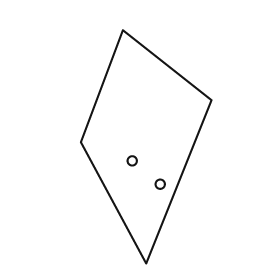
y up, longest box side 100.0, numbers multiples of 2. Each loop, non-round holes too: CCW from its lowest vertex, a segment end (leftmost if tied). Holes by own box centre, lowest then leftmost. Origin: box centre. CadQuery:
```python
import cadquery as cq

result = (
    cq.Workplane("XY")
    .moveTo(0.0, -50.0)
    .lineTo(28.0, 20.0)
    .lineTo(-10.0, 50.0)
    .lineTo(-28.0, 2.0)
    .close()
    .moveTo(6.0, -16.0)
    .circle(2.0)
    .moveTo(-6.0, -6.0)
    .circle(2.0)
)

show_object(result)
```